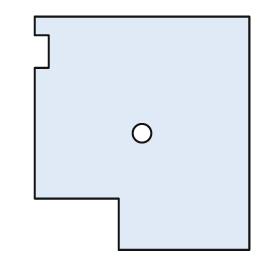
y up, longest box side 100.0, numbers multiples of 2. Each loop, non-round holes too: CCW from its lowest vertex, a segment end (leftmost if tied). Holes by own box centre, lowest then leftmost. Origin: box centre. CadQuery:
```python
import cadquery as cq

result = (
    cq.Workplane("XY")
    .moveTo(-10.0, -50.0)
    .lineTo(46.0, -50.0)
    .lineTo(46.0, 50.0)
    .lineTo(-46.0, 50.0)
    .lineTo(-46.0, 42.0)
    .lineTo(-40.0, 42.0)
    .lineTo(-40.0, 28.0)
    .lineTo(-46.0, 28.0)
    .lineTo(-46.0, -28.0)
    .lineTo(-10.0, -28.0)
    .close()
    .moveTo(0.0, 0.0)
    .circle(4.0)
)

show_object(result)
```